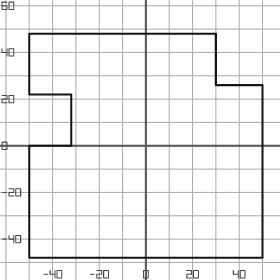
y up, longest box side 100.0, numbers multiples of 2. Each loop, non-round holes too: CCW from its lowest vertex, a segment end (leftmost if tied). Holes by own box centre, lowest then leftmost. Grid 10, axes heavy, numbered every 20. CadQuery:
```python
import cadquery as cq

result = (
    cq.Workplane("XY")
    .moveTo(-50.0, -48.0)
    .lineTo(50.0, -48.0)
    .lineTo(50.0, 26.0)
    .lineTo(30.0, 26.0)
    .lineTo(30.0, 48.0)
    .lineTo(-50.0, 48.0)
    .lineTo(-50.0, 22.0)
    .lineTo(-32.0, 22.0)
    .lineTo(-32.0, 0.0)
    .lineTo(-50.0, 0.0)
    .close()
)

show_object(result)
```